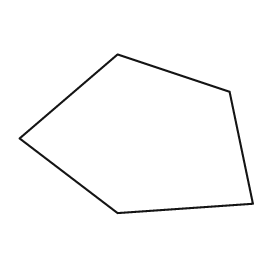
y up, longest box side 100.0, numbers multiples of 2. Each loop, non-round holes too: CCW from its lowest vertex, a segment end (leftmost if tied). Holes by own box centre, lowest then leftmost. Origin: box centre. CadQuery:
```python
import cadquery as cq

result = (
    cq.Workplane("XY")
    .moveTo(-8.0, -34.0)
    .lineTo(50.0, -30.0)
    .lineTo(40.0, 18.0)
    .lineTo(-8.0, 34.0)
    .lineTo(-50.0, -2.0)
    .close()
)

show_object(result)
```